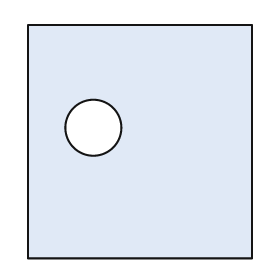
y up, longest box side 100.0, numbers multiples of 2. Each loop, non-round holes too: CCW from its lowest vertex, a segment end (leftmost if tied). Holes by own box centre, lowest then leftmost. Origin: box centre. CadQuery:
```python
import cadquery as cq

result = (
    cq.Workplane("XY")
    .moveTo(-48.0, -50.0)
    .lineTo(48.0, -50.0)
    .lineTo(48.0, 50.0)
    .lineTo(-48.0, 50.0)
    .close()
    .moveTo(-20.0, 6.0)
    .circle(12.0)
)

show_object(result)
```